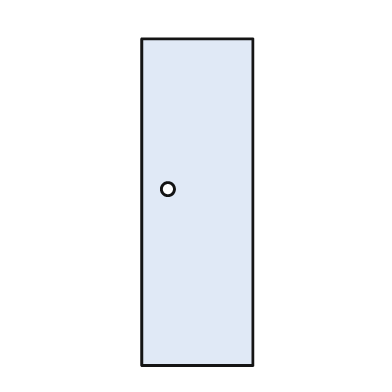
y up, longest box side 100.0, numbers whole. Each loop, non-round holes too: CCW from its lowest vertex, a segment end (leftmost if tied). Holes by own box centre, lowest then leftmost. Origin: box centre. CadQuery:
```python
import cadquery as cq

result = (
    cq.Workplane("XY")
    .moveTo(-17.0, -50.0)
    .lineTo(17.0, -50.0)
    .lineTo(17.0, 50.0)
    .lineTo(-17.0, 50.0)
    .close()
    .moveTo(-9.0, 4.0)
    .circle(2.0)
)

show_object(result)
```